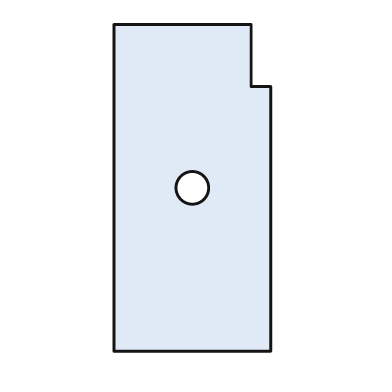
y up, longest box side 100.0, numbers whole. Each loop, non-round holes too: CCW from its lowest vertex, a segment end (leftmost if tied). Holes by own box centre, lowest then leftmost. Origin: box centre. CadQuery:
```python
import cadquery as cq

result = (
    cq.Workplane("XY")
    .moveTo(-24.0, -50.0)
    .lineTo(24.0, -50.0)
    .lineTo(24.0, 31.0)
    .lineTo(18.0, 31.0)
    .lineTo(18.0, 50.0)
    .lineTo(-24.0, 50.0)
    .close()
    .moveTo(0.0, 0.0)
    .circle(5.0)
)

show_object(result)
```